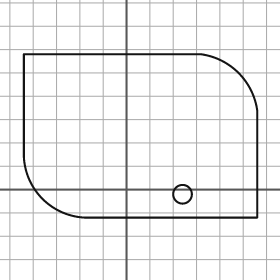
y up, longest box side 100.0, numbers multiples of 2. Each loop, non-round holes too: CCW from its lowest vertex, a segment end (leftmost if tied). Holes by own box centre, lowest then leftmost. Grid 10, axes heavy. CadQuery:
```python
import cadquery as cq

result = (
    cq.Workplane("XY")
    .moveTo(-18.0, -12.0)
    .lineTo(56.0, -12.0)
    .lineTo(56.0, 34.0)
    .threePointArc((48.0, 50.0), (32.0, 58.0))
    .lineTo(-44.0, 58.0)
    .lineTo(-44.0, 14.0)
    .threePointArc((-36.0, -4.0), (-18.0, -12.0))
    .close()
    .moveTo(24.0, -2.0)
    .circle(4.0)
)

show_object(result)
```